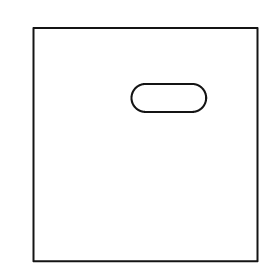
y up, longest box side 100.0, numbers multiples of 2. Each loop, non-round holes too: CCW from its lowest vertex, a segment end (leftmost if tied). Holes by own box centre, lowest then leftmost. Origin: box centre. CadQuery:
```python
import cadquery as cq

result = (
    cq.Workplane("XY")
    .moveTo(-48.0, -50.0)
    .lineTo(48.0, -50.0)
    .lineTo(48.0, 50.0)
    .lineTo(-48.0, 50.0)
    .close()
    .moveTo(0.0, 14.0)
    .lineTo(20.0, 14.0)
    .threePointArc((26.0, 20.0), (20.0, 26.0))
    .lineTo(0.0, 26.0)
    .threePointArc((-6.0, 20.0), (0.0, 14.0))
    .close()
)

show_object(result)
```